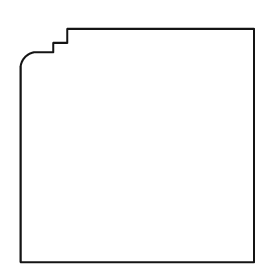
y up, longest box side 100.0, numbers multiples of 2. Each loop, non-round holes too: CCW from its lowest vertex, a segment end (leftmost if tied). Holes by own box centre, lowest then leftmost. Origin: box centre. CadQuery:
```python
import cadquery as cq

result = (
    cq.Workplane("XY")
    .moveTo(-50.0, -50.0)
    .lineTo(50.0, -50.0)
    .lineTo(50.0, 50.0)
    .lineTo(-30.0, 50.0)
    .lineTo(-30.0, 44.0)
    .lineTo(-36.0, 44.0)
    .lineTo(-36.0, 40.0)
    .lineTo(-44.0, 40.0)
    .threePointArc((-48.0, 38.0), (-50.0, 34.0))
    .close()
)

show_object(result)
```